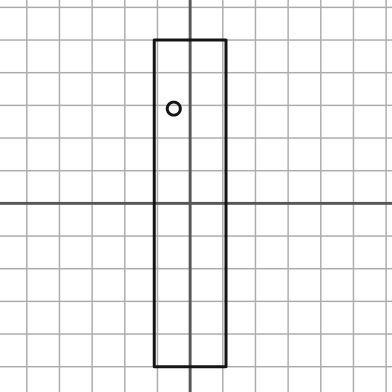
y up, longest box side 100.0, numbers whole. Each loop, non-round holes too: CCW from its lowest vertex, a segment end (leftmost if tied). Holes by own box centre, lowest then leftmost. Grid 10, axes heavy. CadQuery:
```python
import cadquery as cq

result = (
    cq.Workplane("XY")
    .moveTo(-11.0, -50.0)
    .lineTo(11.0, -50.0)
    .lineTo(11.0, 50.0)
    .lineTo(-11.0, 50.0)
    .close()
    .moveTo(-5.0, 29.0)
    .circle(2.0)
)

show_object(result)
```